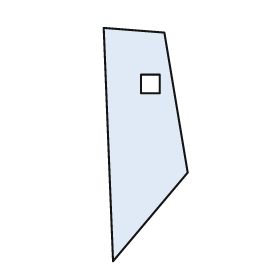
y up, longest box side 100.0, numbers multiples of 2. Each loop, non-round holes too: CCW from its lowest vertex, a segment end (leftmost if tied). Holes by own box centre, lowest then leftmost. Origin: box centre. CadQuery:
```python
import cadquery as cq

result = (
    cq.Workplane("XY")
    .moveTo(-14.0, -50.0)
    .lineTo(18.0, -12.0)
    .lineTo(8.0, 48.0)
    .lineTo(-18.0, 50.0)
    .close()
    .moveTo(-2.0, 22.0)
    .lineTo(6.0, 22.0)
    .lineTo(6.0, 30.0)
    .lineTo(-2.0, 30.0)
    .close()
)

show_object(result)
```